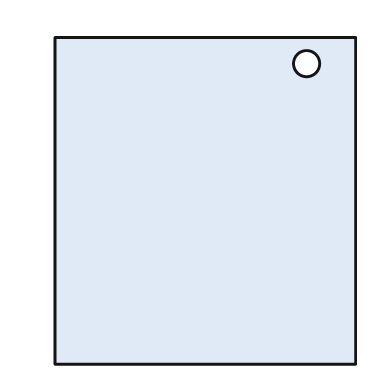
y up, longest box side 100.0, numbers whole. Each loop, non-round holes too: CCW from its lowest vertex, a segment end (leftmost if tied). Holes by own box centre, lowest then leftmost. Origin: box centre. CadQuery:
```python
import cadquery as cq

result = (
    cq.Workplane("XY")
    .moveTo(-46.0, -50.0)
    .lineTo(46.0, -50.0)
    .lineTo(46.0, 50.0)
    .lineTo(-46.0, 50.0)
    .close()
    .moveTo(31.0, 42.0)
    .circle(4.0)
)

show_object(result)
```